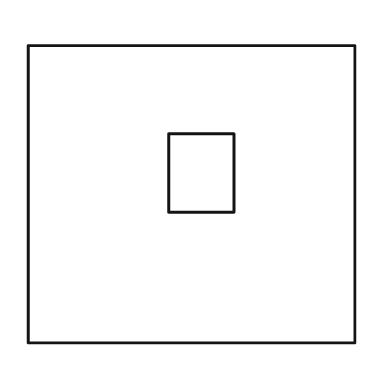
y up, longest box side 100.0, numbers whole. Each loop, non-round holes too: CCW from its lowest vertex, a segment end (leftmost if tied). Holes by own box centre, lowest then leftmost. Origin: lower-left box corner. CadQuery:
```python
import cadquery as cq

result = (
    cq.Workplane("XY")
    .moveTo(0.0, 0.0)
    .lineTo(100.0, 0.0)
    .lineTo(100.0, 91.0)
    .lineTo(0.0, 91.0)
    .close()
    .moveTo(43.0, 40.0)
    .lineTo(63.0, 40.0)
    .lineTo(63.0, 64.0)
    .lineTo(43.0, 64.0)
    .close()
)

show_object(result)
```